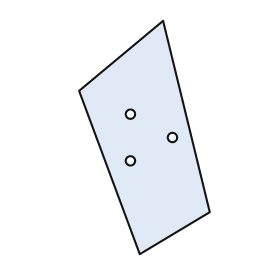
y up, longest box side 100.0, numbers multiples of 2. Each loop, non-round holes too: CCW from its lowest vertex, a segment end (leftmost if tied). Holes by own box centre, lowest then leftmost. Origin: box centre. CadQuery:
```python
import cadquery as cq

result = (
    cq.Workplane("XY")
    .moveTo(-2.0, -50.0)
    .lineTo(28.0, -32.0)
    .lineTo(8.0, 50.0)
    .lineTo(-28.0, 20.0)
    .close()
    .moveTo(-6.0, -10.0)
    .circle(2.0)
    .moveTo(12.0, 0.0)
    .circle(2.0)
    .moveTo(-6.0, 10.0)
    .circle(2.0)
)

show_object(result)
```